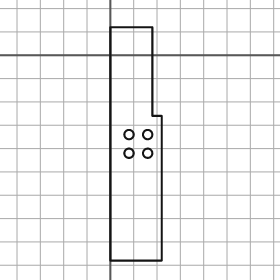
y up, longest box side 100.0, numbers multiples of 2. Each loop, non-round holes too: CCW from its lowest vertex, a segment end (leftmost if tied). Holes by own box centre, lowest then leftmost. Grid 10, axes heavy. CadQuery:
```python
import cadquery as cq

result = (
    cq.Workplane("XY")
    .moveTo(0.0, -88.0)
    .lineTo(22.0, -88.0)
    .lineTo(22.0, -26.0)
    .lineTo(18.0, -26.0)
    .lineTo(18.0, 12.0)
    .lineTo(0.0, 12.0)
    .close()
    .moveTo(8.0, -42.0)
    .circle(2.0)
    .moveTo(16.0, -42.0)
    .circle(2.0)
    .moveTo(8.0, -34.0)
    .circle(2.0)
    .moveTo(16.0, -34.0)
    .circle(2.0)
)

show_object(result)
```